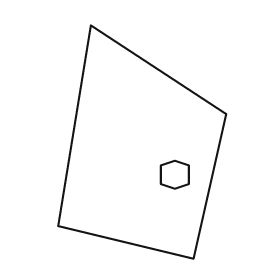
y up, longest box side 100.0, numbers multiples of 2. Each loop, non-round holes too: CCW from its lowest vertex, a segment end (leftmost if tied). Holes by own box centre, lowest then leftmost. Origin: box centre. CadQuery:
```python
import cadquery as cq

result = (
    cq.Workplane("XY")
    .moveTo(22.0, -50.0)
    .lineTo(36.0, 12.0)
    .lineTo(-22.0, 50.0)
    .lineTo(-36.0, -36.0)
    .close()
    .moveTo(14.0, -20.0)
    .lineTo(20.0, -18.0)
    .lineTo(20.0, -10.0)
    .lineTo(14.0, -8.0)
    .lineTo(8.0, -10.0)
    .lineTo(8.0, -18.0)
    .close()
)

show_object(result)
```